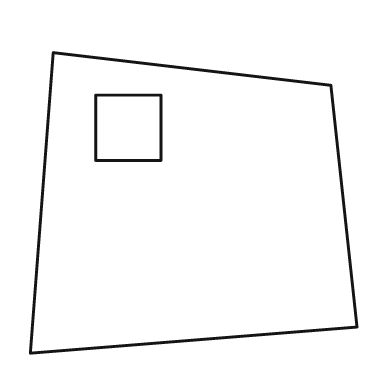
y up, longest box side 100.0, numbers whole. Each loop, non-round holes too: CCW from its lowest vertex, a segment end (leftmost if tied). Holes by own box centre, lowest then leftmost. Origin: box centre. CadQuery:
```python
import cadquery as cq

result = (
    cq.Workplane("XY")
    .moveTo(-50.0, -46.0)
    .lineTo(50.0, -38.0)
    .lineTo(42.0, 36.0)
    .lineTo(-43.0, 46.0)
    .close()
    .moveTo(-30.0, 13.0)
    .lineTo(-10.0, 13.0)
    .lineTo(-10.0, 33.0)
    .lineTo(-30.0, 33.0)
    .close()
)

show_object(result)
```